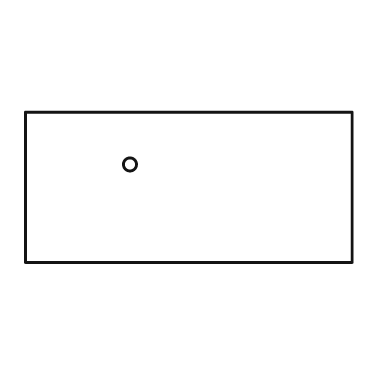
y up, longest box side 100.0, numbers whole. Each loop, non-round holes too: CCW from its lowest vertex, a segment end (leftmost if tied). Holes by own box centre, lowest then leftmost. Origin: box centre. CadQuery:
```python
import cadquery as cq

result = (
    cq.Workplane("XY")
    .moveTo(-50.0, -23.0)
    .lineTo(50.0, -23.0)
    .lineTo(50.0, 23.0)
    .lineTo(-50.0, 23.0)
    .close()
    .moveTo(-18.0, 7.0)
    .circle(2.0)
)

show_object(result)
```